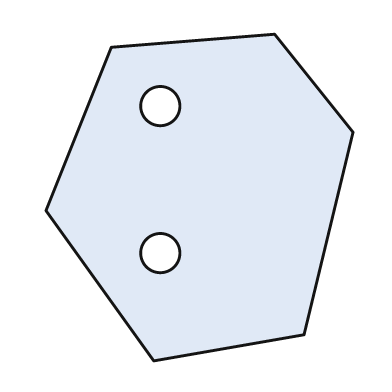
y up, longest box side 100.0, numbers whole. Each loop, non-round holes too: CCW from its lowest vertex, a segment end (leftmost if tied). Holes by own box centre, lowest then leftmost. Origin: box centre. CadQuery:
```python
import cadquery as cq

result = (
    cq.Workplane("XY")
    .moveTo(-14.0, -50.0)
    .lineTo(32.0, -42.0)
    .lineTo(47.0, 20.0)
    .lineTo(23.0, 50.0)
    .lineTo(-27.0, 46.0)
    .lineTo(-47.0, -4.0)
    .close()
    .moveTo(-12.0, -17.0)
    .circle(6.0)
    .moveTo(-12.0, 28.0)
    .circle(6.0)
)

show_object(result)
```